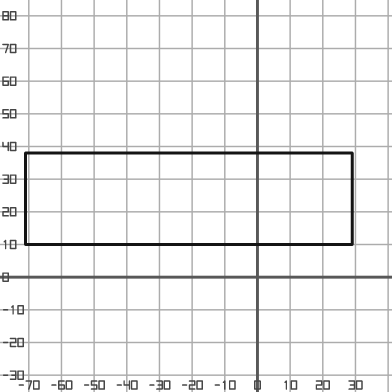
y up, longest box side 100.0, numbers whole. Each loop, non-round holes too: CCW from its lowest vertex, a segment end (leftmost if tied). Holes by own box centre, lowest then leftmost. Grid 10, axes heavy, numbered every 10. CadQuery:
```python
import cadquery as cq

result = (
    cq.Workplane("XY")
    .moveTo(-71.0, 10.0)
    .lineTo(29.0, 10.0)
    .lineTo(29.0, 38.0)
    .lineTo(-71.0, 38.0)
    .close()
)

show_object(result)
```